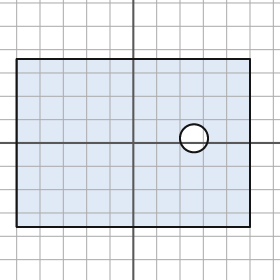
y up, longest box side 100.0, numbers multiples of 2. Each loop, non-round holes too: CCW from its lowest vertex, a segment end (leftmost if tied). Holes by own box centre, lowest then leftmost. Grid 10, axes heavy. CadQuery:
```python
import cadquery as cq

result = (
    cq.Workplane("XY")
    .moveTo(-50.0, -36.0)
    .lineTo(50.0, -36.0)
    .lineTo(50.0, 36.0)
    .lineTo(-50.0, 36.0)
    .close()
    .moveTo(26.0, 2.0)
    .circle(6.0)
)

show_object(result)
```